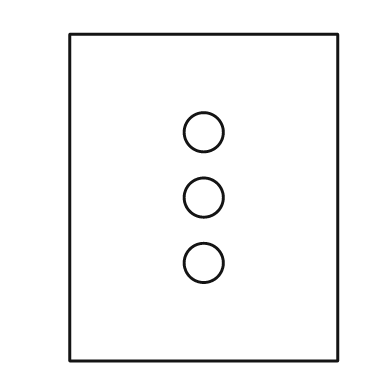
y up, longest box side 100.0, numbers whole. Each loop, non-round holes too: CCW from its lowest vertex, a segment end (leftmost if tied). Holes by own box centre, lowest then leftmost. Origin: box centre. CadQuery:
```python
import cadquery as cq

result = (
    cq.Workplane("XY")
    .moveTo(-41.0, -50.0)
    .lineTo(41.0, -50.0)
    .lineTo(41.0, 50.0)
    .lineTo(-41.0, 50.0)
    .close()
    .moveTo(0.0, -20.0)
    .circle(6.0)
    .moveTo(0.0, 0.0)
    .circle(6.0)
    .moveTo(0.0, 20.0)
    .circle(6.0)
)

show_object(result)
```